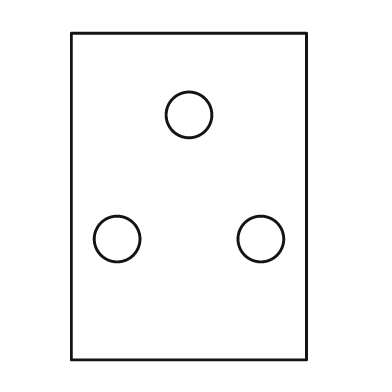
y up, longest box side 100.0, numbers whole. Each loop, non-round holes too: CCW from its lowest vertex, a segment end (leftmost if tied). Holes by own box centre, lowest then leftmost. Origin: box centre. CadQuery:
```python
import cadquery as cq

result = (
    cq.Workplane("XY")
    .moveTo(-36.0, -50.0)
    .lineTo(36.0, -50.0)
    .lineTo(36.0, 50.0)
    .lineTo(-36.0, 50.0)
    .close()
    .moveTo(-22.0, -13.0)
    .circle(7.0)
    .moveTo(22.0, -13.0)
    .circle(7.0)
    .moveTo(0.0, 25.0)
    .circle(7.0)
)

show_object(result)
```